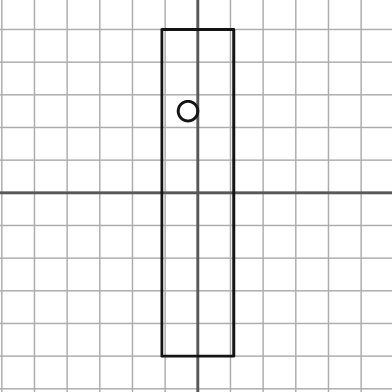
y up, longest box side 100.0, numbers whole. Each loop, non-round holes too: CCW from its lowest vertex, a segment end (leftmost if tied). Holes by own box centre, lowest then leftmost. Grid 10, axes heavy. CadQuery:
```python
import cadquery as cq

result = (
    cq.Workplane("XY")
    .moveTo(-11.0, -50.0)
    .lineTo(11.0, -50.0)
    .lineTo(11.0, 50.0)
    .lineTo(-11.0, 50.0)
    .close()
    .moveTo(-3.0, 25.0)
    .circle(3.0)
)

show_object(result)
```